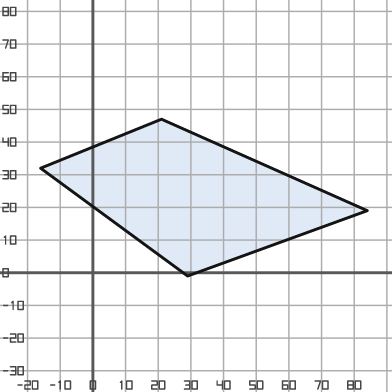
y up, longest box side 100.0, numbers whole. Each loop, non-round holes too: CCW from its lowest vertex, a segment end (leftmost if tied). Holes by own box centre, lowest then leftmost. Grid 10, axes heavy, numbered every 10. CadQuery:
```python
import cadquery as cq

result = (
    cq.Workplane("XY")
    .moveTo(29.0, -1.0)
    .lineTo(84.0, 19.0)
    .lineTo(21.0, 47.0)
    .lineTo(-16.0, 32.0)
    .close()
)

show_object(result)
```